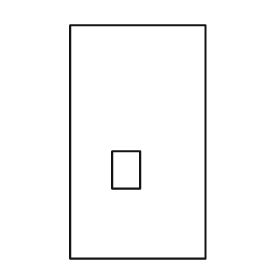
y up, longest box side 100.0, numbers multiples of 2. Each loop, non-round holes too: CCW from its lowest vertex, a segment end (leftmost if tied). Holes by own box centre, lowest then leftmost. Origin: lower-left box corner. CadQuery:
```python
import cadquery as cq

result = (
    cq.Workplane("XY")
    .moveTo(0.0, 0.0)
    .lineTo(58.0, 0.0)
    .lineTo(58.0, 100.0)
    .lineTo(0.0, 100.0)
    .close()
    .moveTo(18.0, 30.0)
    .lineTo(30.0, 30.0)
    .lineTo(30.0, 46.0)
    .lineTo(18.0, 46.0)
    .close()
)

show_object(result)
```